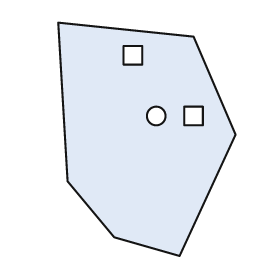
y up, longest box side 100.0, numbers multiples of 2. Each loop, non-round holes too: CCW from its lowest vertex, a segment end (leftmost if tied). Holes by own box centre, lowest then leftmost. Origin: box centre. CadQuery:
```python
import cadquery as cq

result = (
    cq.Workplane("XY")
    .moveTo(14.0, -50.0)
    .lineTo(38.0, 2.0)
    .lineTo(20.0, 44.0)
    .lineTo(-38.0, 50.0)
    .lineTo(-34.0, -18.0)
    .lineTo(-14.0, -42.0)
    .close()
    .moveTo(4.0, 10.0)
    .circle(4.0)
    .moveTo(16.0, 6.0)
    .lineTo(24.0, 6.0)
    .lineTo(24.0, 14.0)
    .lineTo(16.0, 14.0)
    .close()
    .moveTo(-10.0, 32.0)
    .lineTo(-2.0, 32.0)
    .lineTo(-2.0, 40.0)
    .lineTo(-10.0, 40.0)
    .close()
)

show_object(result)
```